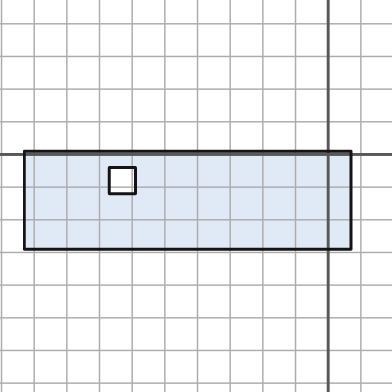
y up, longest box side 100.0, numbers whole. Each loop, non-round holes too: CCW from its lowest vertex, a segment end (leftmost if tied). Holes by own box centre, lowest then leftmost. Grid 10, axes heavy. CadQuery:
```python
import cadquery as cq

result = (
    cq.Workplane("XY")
    .moveTo(-93.0, -29.0)
    .lineTo(7.0, -29.0)
    .lineTo(7.0, 1.0)
    .lineTo(-93.0, 1.0)
    .close()
    .moveTo(-67.0, -12.0)
    .lineTo(-59.0, -12.0)
    .lineTo(-59.0, -4.0)
    .lineTo(-67.0, -4.0)
    .close()
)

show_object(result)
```